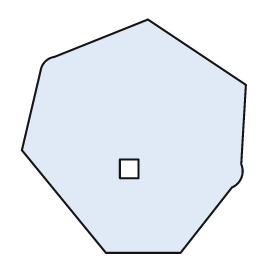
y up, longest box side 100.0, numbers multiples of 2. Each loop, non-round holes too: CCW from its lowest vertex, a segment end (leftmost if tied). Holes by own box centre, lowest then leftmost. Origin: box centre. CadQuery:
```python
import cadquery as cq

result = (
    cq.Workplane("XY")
    .moveTo(-12.0, -50.0)
    .lineTo(20.0, -50.0)
    .lineTo(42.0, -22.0)
    .threePointArc((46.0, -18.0), (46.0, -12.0))
    .lineTo(48.0, 22.0)
    .lineTo(6.0, 50.0)
    .lineTo(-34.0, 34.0)
    .threePointArc((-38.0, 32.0), (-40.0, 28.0))
    .lineTo(-48.0, -6.0)
    .close()
    .moveTo(-6.0, -18.0)
    .lineTo(2.0, -18.0)
    .lineTo(2.0, -10.0)
    .lineTo(-6.0, -10.0)
    .close()
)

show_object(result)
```